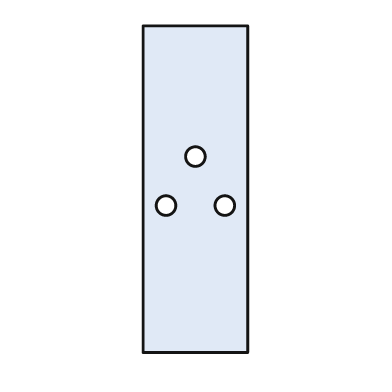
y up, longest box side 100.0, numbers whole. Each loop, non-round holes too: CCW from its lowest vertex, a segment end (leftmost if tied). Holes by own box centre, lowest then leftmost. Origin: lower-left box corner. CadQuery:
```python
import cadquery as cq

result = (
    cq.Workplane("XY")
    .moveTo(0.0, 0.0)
    .lineTo(32.0, 0.0)
    .lineTo(32.0, 100.0)
    .lineTo(0.0, 100.0)
    .close()
    .moveTo(7.0, 45.0)
    .circle(3.0)
    .moveTo(25.0, 45.0)
    .circle(3.0)
    .moveTo(16.0, 60.0)
    .circle(3.0)
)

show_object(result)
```